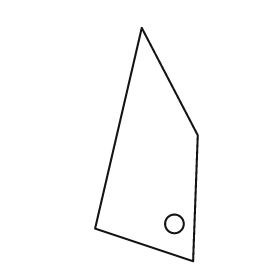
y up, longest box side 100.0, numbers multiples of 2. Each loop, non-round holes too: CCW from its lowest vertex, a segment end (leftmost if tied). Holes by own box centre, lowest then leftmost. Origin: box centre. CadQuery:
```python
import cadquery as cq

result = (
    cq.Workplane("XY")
    .moveTo(20.0, -50.0)
    .lineTo(22.0, 4.0)
    .lineTo(-2.0, 50.0)
    .lineTo(-22.0, -36.0)
    .close()
    .moveTo(12.0, -34.0)
    .circle(4.0)
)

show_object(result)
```